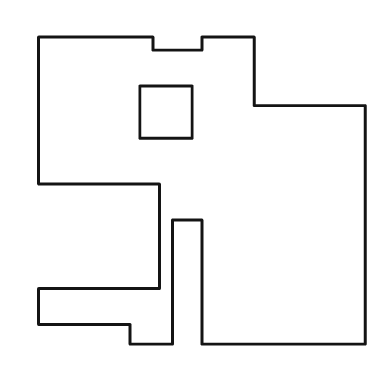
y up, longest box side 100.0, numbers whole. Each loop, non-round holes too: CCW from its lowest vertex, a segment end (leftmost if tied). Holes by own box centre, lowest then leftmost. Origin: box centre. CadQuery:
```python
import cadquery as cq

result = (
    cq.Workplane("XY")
    .moveTo(-22.0, -47.0)
    .lineTo(-9.0, -47.0)
    .lineTo(-9.0, -9.0)
    .lineTo(0.0, -9.0)
    .lineTo(0.0, -47.0)
    .lineTo(50.0, -47.0)
    .lineTo(50.0, 26.0)
    .lineTo(16.0, 26.0)
    .lineTo(16.0, 47.0)
    .lineTo(0.0, 47.0)
    .lineTo(0.0, 43.0)
    .lineTo(-15.0, 43.0)
    .lineTo(-15.0, 47.0)
    .lineTo(-50.0, 47.0)
    .lineTo(-50.0, 2.0)
    .lineTo(-13.0, 2.0)
    .lineTo(-13.0, -30.0)
    .lineTo(-50.0, -30.0)
    .lineTo(-50.0, -41.0)
    .lineTo(-22.0, -41.0)
    .close()
    .moveTo(-19.0, 16.0)
    .lineTo(-3.0, 16.0)
    .lineTo(-3.0, 32.0)
    .lineTo(-19.0, 32.0)
    .close()
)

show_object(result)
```